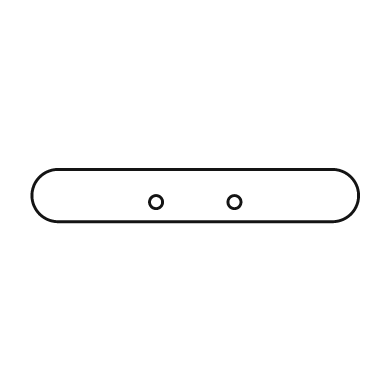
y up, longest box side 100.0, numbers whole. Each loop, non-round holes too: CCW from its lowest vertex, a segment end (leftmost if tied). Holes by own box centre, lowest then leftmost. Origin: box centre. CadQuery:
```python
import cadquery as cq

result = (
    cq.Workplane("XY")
    .moveTo(-42.0, -8.0)
    .lineTo(42.0, -8.0)
    .threePointArc((50.0, 0.0), (42.0, 8.0))
    .lineTo(-42.0, 8.0)
    .threePointArc((-50.0, 0.0), (-42.0, -8.0))
    .close()
    .moveTo(-12.0, -2.0)
    .circle(2.0)
    .moveTo(12.0, -2.0)
    .circle(2.0)
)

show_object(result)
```